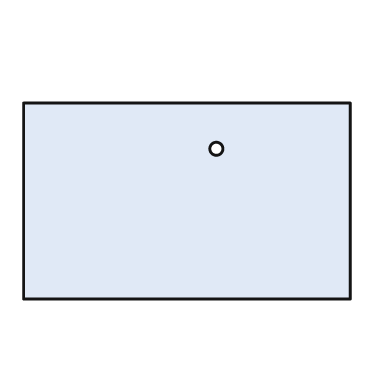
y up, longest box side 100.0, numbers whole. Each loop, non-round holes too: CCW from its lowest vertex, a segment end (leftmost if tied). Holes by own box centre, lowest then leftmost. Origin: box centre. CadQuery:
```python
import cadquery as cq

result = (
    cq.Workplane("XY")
    .moveTo(-50.0, -30.0)
    .lineTo(50.0, -30.0)
    .lineTo(50.0, 30.0)
    .lineTo(-50.0, 30.0)
    .close()
    .moveTo(9.0, 16.0)
    .circle(2.0)
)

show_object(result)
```